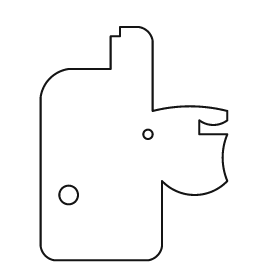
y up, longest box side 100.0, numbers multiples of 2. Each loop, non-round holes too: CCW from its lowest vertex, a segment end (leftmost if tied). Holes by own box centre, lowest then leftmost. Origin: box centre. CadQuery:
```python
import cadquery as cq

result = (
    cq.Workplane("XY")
    .moveTo(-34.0, -50.0)
    .lineTo(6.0, -50.0)
    .threePointArc((10.0, -48.0), (12.0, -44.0))
    .lineTo(12.0, -16.0)
    .threePointArc((26.0, -22.0), (40.0, -16.0))
    .threePointArc((38.0, -6.0), (40.0, 4.0))
    .lineTo(28.0, 4.0)
    .lineTo(28.0, 10.0)
    .threePointArc((34.0, 8.0), (40.0, 10.0))
    .lineTo(40.0, 14.0)
    .threePointArc((24.0, 16.0), (8.0, 14.0))
    .lineTo(8.0, 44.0)
    .threePointArc((6.0, 48.0), (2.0, 50.0))
    .lineTo(-6.0, 50.0)
    .lineTo(-6.0, 46.0)
    .lineTo(-10.0, 46.0)
    .lineTo(-10.0, 32.0)
    .lineTo(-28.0, 32.0)
    .threePointArc((-36.0, 28.0), (-40.0, 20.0))
    .lineTo(-40.0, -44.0)
    .threePointArc((-38.0, -48.0), (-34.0, -50.0))
    .close()
    .moveTo(-28.0, -22.0)
    .circle(4.0)
    .moveTo(6.0, 4.0)
    .circle(2.0)
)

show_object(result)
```